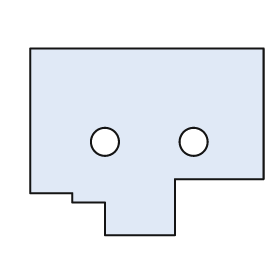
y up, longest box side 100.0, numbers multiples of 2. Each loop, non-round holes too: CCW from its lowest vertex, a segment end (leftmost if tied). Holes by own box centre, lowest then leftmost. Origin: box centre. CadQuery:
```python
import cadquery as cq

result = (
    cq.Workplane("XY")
    .moveTo(-18.0, -40.0)
    .lineTo(12.0, -40.0)
    .lineTo(12.0, -16.0)
    .lineTo(50.0, -16.0)
    .lineTo(50.0, 40.0)
    .lineTo(-50.0, 40.0)
    .lineTo(-50.0, -22.0)
    .lineTo(-32.0, -22.0)
    .lineTo(-32.0, -26.0)
    .lineTo(-18.0, -26.0)
    .close()
    .moveTo(-18.0, 0.0)
    .circle(6.0)
    .moveTo(20.0, 0.0)
    .circle(6.0)
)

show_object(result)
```